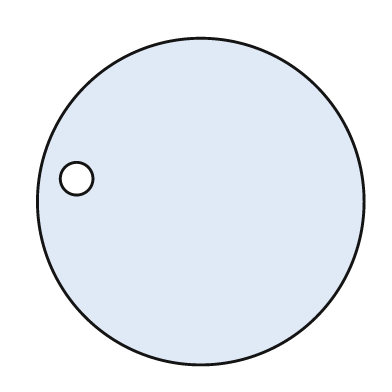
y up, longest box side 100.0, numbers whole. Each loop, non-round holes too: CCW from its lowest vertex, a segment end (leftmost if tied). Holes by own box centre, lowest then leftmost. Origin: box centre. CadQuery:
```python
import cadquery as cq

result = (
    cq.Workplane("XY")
    .moveTo(0.0, 0.0)
    .circle(50.0)
    .moveTo(-38.0, 7.0)
    .circle(5.0)
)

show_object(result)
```